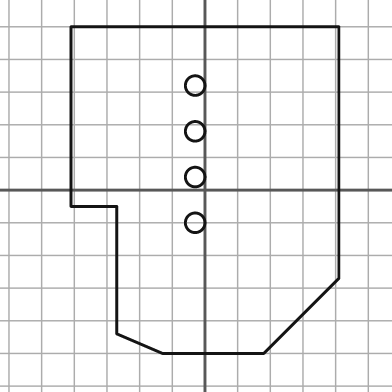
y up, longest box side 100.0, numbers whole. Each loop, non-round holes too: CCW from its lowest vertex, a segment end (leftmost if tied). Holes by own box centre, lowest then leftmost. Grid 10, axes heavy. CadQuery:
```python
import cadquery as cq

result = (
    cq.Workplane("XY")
    .moveTo(-13.0, -50.0)
    .lineTo(18.0, -50.0)
    .lineTo(41.0, -27.0)
    .lineTo(41.0, 50.0)
    .lineTo(-41.0, 50.0)
    .lineTo(-41.0, -5.0)
    .lineTo(-27.0, -5.0)
    .lineTo(-27.0, -44.0)
    .close()
    .moveTo(-3.0, -10.0)
    .circle(3.0)
    .moveTo(-3.0, 4.0)
    .circle(3.0)
    .moveTo(-3.0, 18.0)
    .circle(3.0)
    .moveTo(-3.0, 32.0)
    .circle(3.0)
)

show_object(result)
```